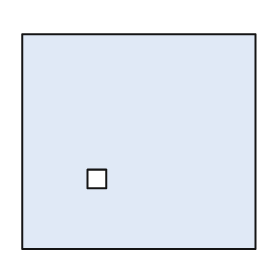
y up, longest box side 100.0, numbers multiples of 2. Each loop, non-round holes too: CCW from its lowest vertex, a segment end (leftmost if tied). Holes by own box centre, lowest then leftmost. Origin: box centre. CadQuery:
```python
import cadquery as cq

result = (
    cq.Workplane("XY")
    .moveTo(-50.0, -46.0)
    .lineTo(50.0, -46.0)
    .lineTo(50.0, 46.0)
    .lineTo(-50.0, 46.0)
    .close()
    .moveTo(-22.0, -20.0)
    .lineTo(-14.0, -20.0)
    .lineTo(-14.0, -12.0)
    .lineTo(-22.0, -12.0)
    .close()
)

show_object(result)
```